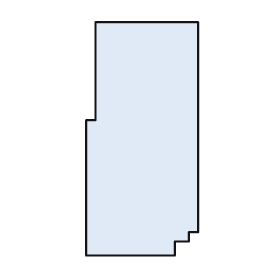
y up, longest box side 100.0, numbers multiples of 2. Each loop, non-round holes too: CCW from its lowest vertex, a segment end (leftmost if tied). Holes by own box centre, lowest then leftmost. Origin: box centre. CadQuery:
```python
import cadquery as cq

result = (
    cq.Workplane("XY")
    .moveTo(-24.0, -50.0)
    .lineTo(14.0, -50.0)
    .lineTo(14.0, -44.0)
    .lineTo(20.0, -44.0)
    .lineTo(20.0, -40.0)
    .lineTo(24.0, -40.0)
    .lineTo(24.0, 50.0)
    .lineTo(-20.0, 50.0)
    .lineTo(-20.0, 8.0)
    .lineTo(-24.0, 8.0)
    .close()
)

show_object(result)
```